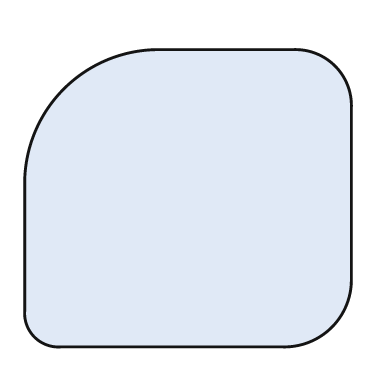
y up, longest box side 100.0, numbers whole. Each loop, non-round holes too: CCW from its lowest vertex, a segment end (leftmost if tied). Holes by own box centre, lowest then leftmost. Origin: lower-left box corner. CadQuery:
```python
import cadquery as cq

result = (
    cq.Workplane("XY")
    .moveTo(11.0, 0.0)
    .lineTo(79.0, 0.0)
    .threePointArc((94.0, 6.0), (100.0, 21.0))
    .lineTo(100.0, 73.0)
    .threePointArc((95.0, 86.0), (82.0, 91.0))
    .lineTo(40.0, 91.0)
    .threePointArc((12.0, 79.0), (0.0, 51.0))
    .lineTo(0.0, 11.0)
    .threePointArc((3.0, 3.0), (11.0, 0.0))
    .close()
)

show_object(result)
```